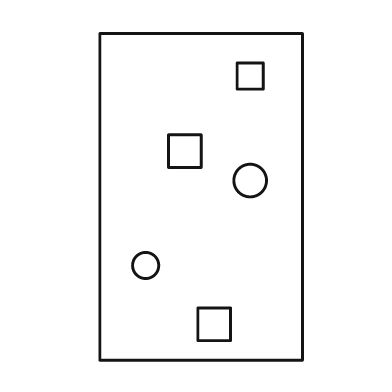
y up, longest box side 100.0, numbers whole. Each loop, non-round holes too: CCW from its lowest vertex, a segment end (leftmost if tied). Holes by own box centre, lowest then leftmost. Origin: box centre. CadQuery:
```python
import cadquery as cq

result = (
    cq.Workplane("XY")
    .moveTo(-31.0, -50.0)
    .lineTo(31.0, -50.0)
    .lineTo(31.0, 50.0)
    .lineTo(-31.0, 50.0)
    .close()
    .moveTo(-1.0, -44.0)
    .lineTo(9.0, -44.0)
    .lineTo(9.0, -34.0)
    .lineTo(-1.0, -34.0)
    .close()
    .moveTo(-17.0, -21.0)
    .circle(4.0)
    .moveTo(15.0, 5.0)
    .circle(5.0)
    .moveTo(-10.0, 9.0)
    .lineTo(0.0, 9.0)
    .lineTo(0.0, 19.0)
    .lineTo(-10.0, 19.0)
    .close()
    .moveTo(11.0, 33.0)
    .lineTo(19.0, 33.0)
    .lineTo(19.0, 41.0)
    .lineTo(11.0, 41.0)
    .close()
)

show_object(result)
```